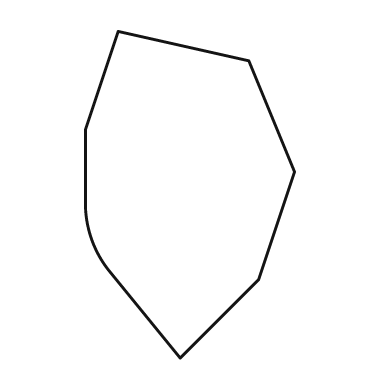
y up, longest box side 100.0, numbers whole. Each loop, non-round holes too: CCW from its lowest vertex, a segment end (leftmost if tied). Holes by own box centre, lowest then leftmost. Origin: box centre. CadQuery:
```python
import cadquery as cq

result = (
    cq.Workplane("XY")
    .moveTo(-3.0, -50.0)
    .lineTo(21.0, -26.0)
    .lineTo(32.0, 7.0)
    .lineTo(18.0, 41.0)
    .lineTo(-22.0, 50.0)
    .lineTo(-32.0, 20.0)
    .lineTo(-32.0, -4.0)
    .threePointArc((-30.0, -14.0), (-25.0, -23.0))
    .close()
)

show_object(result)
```